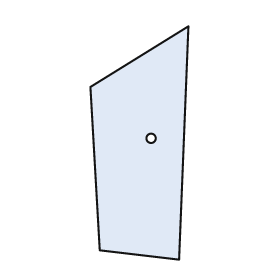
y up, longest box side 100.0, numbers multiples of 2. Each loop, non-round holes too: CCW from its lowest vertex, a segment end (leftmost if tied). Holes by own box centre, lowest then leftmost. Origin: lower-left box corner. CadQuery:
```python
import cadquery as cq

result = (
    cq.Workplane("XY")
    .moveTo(38.0, 0.0)
    .lineTo(42.0, 100.0)
    .lineTo(0.0, 74.0)
    .lineTo(4.0, 4.0)
    .close()
    .moveTo(26.0, 52.0)
    .circle(2.0)
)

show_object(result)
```